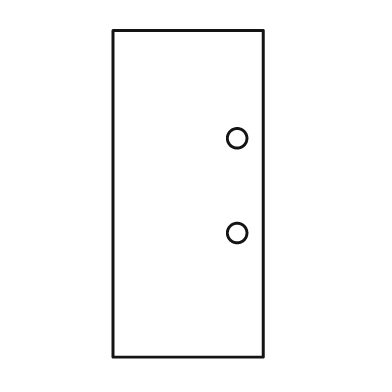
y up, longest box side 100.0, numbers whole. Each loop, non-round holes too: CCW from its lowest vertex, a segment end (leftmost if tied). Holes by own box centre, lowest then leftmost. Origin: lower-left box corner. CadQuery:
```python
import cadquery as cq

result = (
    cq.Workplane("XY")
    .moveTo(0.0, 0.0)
    .lineTo(46.0, 0.0)
    .lineTo(46.0, 100.0)
    .lineTo(0.0, 100.0)
    .close()
    .moveTo(38.0, 38.0)
    .circle(3.0)
    .moveTo(38.0, 67.0)
    .circle(3.0)
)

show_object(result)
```